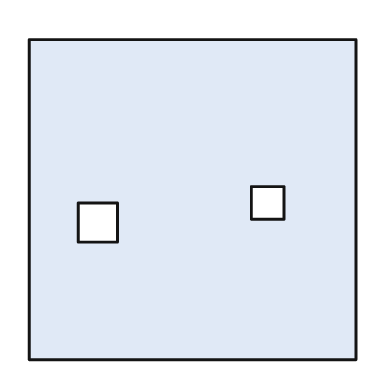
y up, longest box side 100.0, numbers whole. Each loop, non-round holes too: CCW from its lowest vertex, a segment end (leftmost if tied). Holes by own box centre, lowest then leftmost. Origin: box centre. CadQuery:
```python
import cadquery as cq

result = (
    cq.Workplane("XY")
    .moveTo(-50.0, -49.0)
    .lineTo(50.0, -49.0)
    .lineTo(50.0, 49.0)
    .lineTo(-50.0, 49.0)
    .close()
    .moveTo(-35.0, -13.0)
    .lineTo(-23.0, -13.0)
    .lineTo(-23.0, -1.0)
    .lineTo(-35.0, -1.0)
    .close()
    .moveTo(18.0, -6.0)
    .lineTo(28.0, -6.0)
    .lineTo(28.0, 4.0)
    .lineTo(18.0, 4.0)
    .close()
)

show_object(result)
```